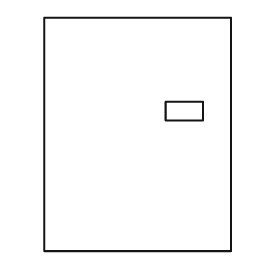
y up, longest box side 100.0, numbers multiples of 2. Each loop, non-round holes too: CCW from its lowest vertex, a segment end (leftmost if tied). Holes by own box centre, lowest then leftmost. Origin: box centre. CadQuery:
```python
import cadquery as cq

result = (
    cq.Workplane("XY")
    .moveTo(-40.0, -50.0)
    .lineTo(40.0, -50.0)
    .lineTo(40.0, 50.0)
    .lineTo(-40.0, 50.0)
    .close()
    .moveTo(12.0, 6.0)
    .lineTo(28.0, 6.0)
    .lineTo(28.0, 14.0)
    .lineTo(12.0, 14.0)
    .close()
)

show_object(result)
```